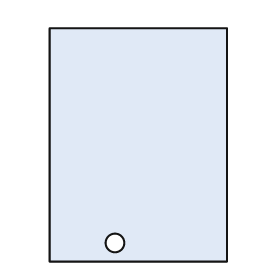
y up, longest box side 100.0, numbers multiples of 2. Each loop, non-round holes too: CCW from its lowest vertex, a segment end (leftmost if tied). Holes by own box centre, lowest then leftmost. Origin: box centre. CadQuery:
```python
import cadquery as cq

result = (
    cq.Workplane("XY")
    .moveTo(-38.0, -50.0)
    .lineTo(38.0, -50.0)
    .lineTo(38.0, 50.0)
    .lineTo(-38.0, 50.0)
    .close()
    .moveTo(-10.0, -42.0)
    .circle(4.0)
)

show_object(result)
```